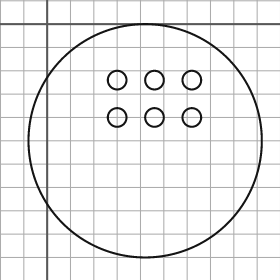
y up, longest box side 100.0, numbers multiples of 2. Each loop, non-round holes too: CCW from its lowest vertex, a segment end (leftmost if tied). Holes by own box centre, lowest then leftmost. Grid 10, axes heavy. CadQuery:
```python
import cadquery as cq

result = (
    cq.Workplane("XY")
    .moveTo(42.0, -50.0)
    .circle(50.0)
    .moveTo(30.0, -40.0)
    .circle(4.0)
    .moveTo(46.0, -40.0)
    .circle(4.0)
    .moveTo(62.0, -40.0)
    .circle(4.0)
    .moveTo(30.0, -24.0)
    .circle(4.0)
    .moveTo(46.0, -24.0)
    .circle(4.0)
    .moveTo(62.0, -24.0)
    .circle(4.0)
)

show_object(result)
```